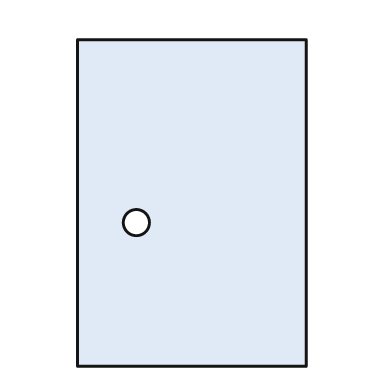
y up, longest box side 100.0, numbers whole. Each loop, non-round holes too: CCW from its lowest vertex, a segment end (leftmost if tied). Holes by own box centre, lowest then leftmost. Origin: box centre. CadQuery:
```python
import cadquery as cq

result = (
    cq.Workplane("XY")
    .moveTo(-35.0, -50.0)
    .lineTo(35.0, -50.0)
    .lineTo(35.0, 50.0)
    .lineTo(-35.0, 50.0)
    .close()
    .moveTo(-17.0, -6.0)
    .circle(4.0)
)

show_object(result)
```